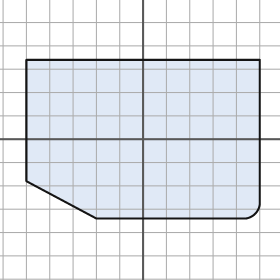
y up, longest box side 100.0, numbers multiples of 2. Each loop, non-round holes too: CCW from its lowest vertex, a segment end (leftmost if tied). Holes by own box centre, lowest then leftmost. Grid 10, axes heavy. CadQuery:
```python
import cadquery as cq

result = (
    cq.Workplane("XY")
    .moveTo(-20.0, -34.0)
    .lineTo(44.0, -34.0)
    .threePointArc((48.0, -32.0), (50.0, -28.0))
    .lineTo(50.0, 34.0)
    .lineTo(-50.0, 34.0)
    .lineTo(-50.0, -18.0)
    .close()
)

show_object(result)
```